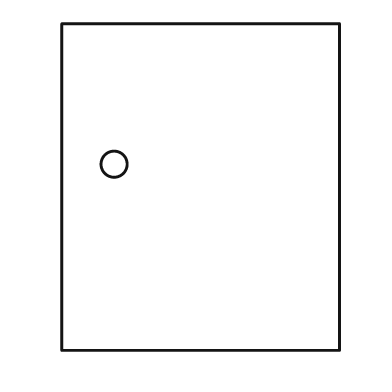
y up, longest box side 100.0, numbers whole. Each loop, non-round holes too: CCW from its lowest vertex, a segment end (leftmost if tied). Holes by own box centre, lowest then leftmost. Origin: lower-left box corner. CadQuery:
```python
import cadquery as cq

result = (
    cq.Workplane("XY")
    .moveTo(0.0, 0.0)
    .lineTo(85.0, 0.0)
    .lineTo(85.0, 100.0)
    .lineTo(0.0, 100.0)
    .close()
    .moveTo(16.0, 57.0)
    .circle(4.0)
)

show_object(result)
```